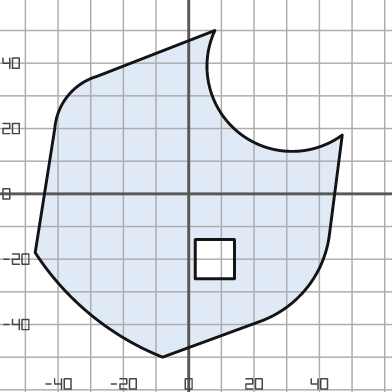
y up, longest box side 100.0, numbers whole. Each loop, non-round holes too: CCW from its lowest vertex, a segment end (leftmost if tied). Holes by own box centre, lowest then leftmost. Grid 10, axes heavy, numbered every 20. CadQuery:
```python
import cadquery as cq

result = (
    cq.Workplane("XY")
    .moveTo(-8.0, -50.0)
    .lineTo(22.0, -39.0)
    .threePointArc((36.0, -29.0), (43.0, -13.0))
    .lineTo(47.0, 18.0)
    .threePointArc((15.0, 19.0), (8.0, 50.0))
    .lineTo(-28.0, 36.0)
    .threePointArc((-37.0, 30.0), (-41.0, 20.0))
    .lineTo(-47.0, -18.0)
    .threePointArc((-30.0, -37.0), (-8.0, -50.0))
    .close()
    .moveTo(2.0, -26.0)
    .lineTo(14.0, -26.0)
    .lineTo(14.0, -14.0)
    .lineTo(2.0, -14.0)
    .close()
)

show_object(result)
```